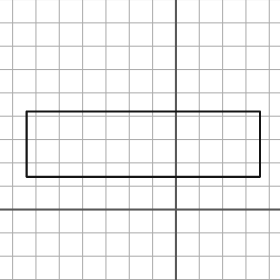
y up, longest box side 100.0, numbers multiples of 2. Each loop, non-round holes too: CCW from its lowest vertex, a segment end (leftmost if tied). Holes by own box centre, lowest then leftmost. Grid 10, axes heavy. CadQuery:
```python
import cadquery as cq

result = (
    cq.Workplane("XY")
    .moveTo(-64.0, 14.0)
    .lineTo(36.0, 14.0)
    .lineTo(36.0, 42.0)
    .lineTo(-64.0, 42.0)
    .close()
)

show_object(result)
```